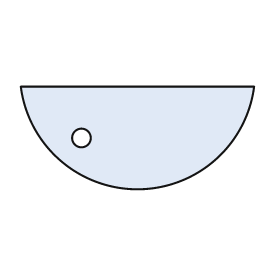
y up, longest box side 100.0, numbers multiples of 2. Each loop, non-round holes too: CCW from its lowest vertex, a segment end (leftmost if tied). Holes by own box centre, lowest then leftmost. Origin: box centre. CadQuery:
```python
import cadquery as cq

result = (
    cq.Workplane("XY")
    .moveTo(-50.0, 22.0)
    .threePointArc((0.0, -22.0), (50.0, 22.0))
    .close()
    .moveTo(-24.0, 0.0)
    .circle(4.0)
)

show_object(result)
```